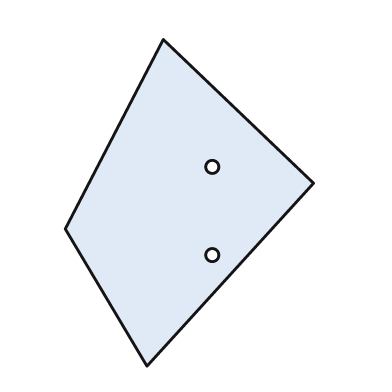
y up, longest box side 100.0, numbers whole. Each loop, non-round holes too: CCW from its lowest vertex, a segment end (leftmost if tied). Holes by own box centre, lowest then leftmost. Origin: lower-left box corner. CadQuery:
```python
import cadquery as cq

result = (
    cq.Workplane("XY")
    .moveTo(25.0, 0.0)
    .lineTo(76.0, 56.0)
    .lineTo(30.0, 100.0)
    .lineTo(0.0, 42.0)
    .close()
    .moveTo(45.0, 34.0)
    .circle(2.0)
    .moveTo(45.0, 61.0)
    .circle(2.0)
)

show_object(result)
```